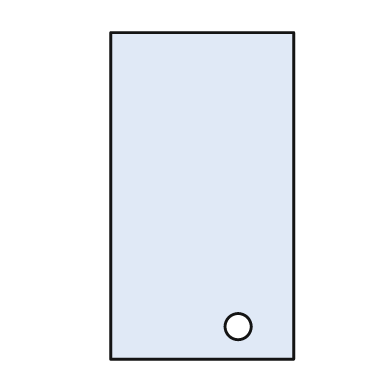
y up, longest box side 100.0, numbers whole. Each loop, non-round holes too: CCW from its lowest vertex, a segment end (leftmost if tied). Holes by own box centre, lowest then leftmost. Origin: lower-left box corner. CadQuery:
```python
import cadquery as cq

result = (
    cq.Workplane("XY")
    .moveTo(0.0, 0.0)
    .lineTo(56.0, 0.0)
    .lineTo(56.0, 100.0)
    .lineTo(0.0, 100.0)
    .close()
    .moveTo(39.0, 10.0)
    .circle(4.0)
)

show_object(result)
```